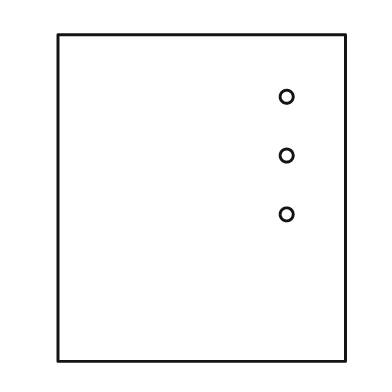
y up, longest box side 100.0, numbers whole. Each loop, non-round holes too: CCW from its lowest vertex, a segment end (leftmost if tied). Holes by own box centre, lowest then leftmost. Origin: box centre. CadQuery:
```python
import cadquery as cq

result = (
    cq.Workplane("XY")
    .moveTo(-44.0, -50.0)
    .lineTo(44.0, -50.0)
    .lineTo(44.0, 50.0)
    .lineTo(-44.0, 50.0)
    .close()
    .moveTo(26.0, -5.0)
    .circle(2.0)
    .moveTo(26.0, 13.0)
    .circle(2.0)
    .moveTo(26.0, 31.0)
    .circle(2.0)
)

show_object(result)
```